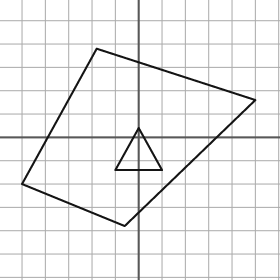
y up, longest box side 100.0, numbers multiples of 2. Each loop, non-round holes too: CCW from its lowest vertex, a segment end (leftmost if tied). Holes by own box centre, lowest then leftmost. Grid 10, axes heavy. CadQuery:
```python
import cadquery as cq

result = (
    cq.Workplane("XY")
    .moveTo(-6.0, -38.0)
    .lineTo(50.0, 16.0)
    .lineTo(-18.0, 38.0)
    .lineTo(-50.0, -20.0)
    .close()
    .moveTo(-10.0, -14.0)
    .lineTo(10.0, -14.0)
    .lineTo(0.0, 4.0)
    .close()
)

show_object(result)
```